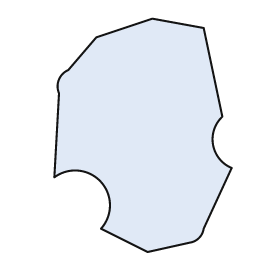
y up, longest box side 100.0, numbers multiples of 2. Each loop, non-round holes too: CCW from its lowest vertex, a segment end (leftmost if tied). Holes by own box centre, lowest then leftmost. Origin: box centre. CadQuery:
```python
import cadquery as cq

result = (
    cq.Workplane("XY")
    .moveTo(2.0, -50.0)
    .lineTo(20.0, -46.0)
    .threePointArc((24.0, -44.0), (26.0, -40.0))
    .lineTo(38.0, -14.0)
    .threePointArc((30.0, -4.0), (34.0, 8.0))
    .lineTo(26.0, 46.0)
    .lineTo(4.0, 50.0)
    .lineTo(-20.0, 42.0)
    .lineTo(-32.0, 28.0)
    .threePointArc((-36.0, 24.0), (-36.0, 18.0))
    .lineTo(-38.0, -18.0)
    .threePointArc((-18.0, -20.0), (-18.0, -40.0))
    .close()
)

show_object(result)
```